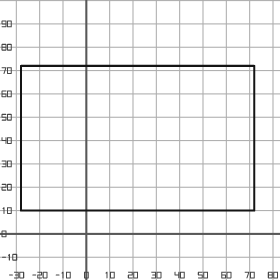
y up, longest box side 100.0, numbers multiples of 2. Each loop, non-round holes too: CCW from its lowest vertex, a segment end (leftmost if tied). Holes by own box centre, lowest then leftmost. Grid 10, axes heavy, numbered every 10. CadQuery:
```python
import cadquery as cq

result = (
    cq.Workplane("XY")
    .moveTo(-28.0, 10.0)
    .lineTo(72.0, 10.0)
    .lineTo(72.0, 72.0)
    .lineTo(-28.0, 72.0)
    .close()
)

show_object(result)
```